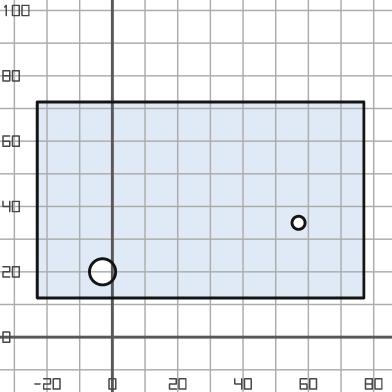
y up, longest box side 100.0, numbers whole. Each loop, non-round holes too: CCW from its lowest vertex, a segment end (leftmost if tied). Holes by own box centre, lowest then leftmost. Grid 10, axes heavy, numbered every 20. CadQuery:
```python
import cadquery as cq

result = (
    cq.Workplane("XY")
    .moveTo(-23.0, 12.0)
    .lineTo(77.0, 12.0)
    .lineTo(77.0, 72.0)
    .lineTo(-23.0, 72.0)
    .close()
    .moveTo(-3.0, 20.0)
    .circle(4.0)
    .moveTo(57.0, 35.0)
    .circle(2.0)
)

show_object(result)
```